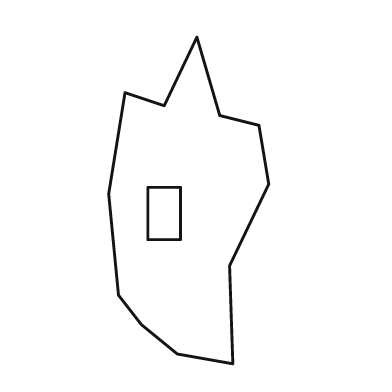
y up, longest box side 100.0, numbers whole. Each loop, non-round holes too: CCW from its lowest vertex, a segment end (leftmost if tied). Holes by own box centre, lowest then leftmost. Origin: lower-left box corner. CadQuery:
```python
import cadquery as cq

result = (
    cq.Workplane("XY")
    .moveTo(38.0, 0.0)
    .lineTo(37.0, 30.0)
    .lineTo(49.0, 55.0)
    .lineTo(46.0, 73.0)
    .lineTo(34.0, 76.0)
    .lineTo(27.0, 100.0)
    .lineTo(17.0, 79.0)
    .lineTo(5.0, 83.0)
    .lineTo(0.0, 52.0)
    .lineTo(3.0, 21.0)
    .lineTo(10.0, 12.0)
    .lineTo(21.0, 3.0)
    .close()
    .moveTo(12.0, 38.0)
    .lineTo(22.0, 38.0)
    .lineTo(22.0, 54.0)
    .lineTo(12.0, 54.0)
    .close()
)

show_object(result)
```